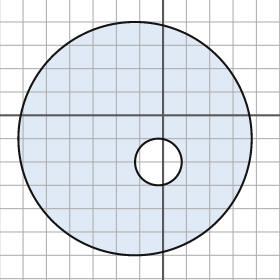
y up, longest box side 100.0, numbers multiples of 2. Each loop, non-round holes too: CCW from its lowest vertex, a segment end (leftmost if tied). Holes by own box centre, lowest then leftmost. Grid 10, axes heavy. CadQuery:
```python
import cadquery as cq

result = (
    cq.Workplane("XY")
    .moveTo(-12.0, -10.0)
    .circle(50.0)
    .moveTo(-2.0, -20.0)
    .circle(10.0)
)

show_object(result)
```